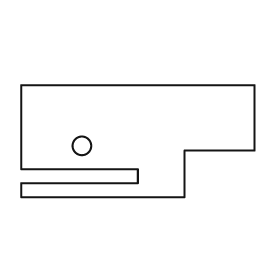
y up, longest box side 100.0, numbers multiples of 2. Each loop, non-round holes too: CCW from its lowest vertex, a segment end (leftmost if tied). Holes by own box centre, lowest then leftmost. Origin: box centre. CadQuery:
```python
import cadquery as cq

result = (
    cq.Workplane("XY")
    .moveTo(-50.0, -24.0)
    .lineTo(20.0, -24.0)
    .lineTo(20.0, -4.0)
    .lineTo(50.0, -4.0)
    .lineTo(50.0, 24.0)
    .lineTo(-50.0, 24.0)
    .lineTo(-50.0, -12.0)
    .lineTo(0.0, -12.0)
    .lineTo(0.0, -18.0)
    .lineTo(-50.0, -18.0)
    .close()
    .moveTo(-24.0, -2.0)
    .circle(4.0)
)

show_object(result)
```